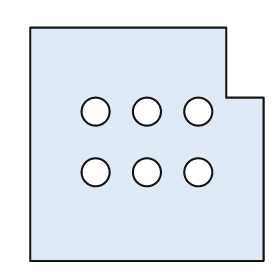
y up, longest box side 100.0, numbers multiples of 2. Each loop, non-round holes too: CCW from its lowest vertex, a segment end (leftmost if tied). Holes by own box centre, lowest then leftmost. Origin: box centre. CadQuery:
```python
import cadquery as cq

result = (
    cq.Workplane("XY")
    .moveTo(-50.0, -50.0)
    .lineTo(50.0, -50.0)
    .lineTo(50.0, 20.0)
    .lineTo(34.0, 20.0)
    .lineTo(34.0, 50.0)
    .lineTo(-50.0, 50.0)
    .close()
    .moveTo(-22.0, -12.0)
    .circle(6.0)
    .moveTo(0.0, -12.0)
    .circle(6.0)
    .moveTo(22.0, -12.0)
    .circle(6.0)
    .moveTo(-22.0, 14.0)
    .circle(6.0)
    .moveTo(0.0, 14.0)
    .circle(6.0)
    .moveTo(22.0, 14.0)
    .circle(6.0)
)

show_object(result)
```